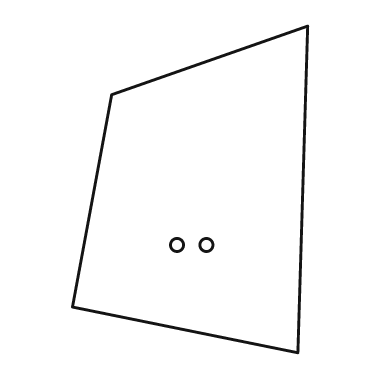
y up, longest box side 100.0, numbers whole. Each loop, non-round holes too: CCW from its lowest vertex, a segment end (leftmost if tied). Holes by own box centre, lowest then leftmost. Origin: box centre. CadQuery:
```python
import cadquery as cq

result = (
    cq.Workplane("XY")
    .moveTo(33.0, -50.0)
    .lineTo(36.0, 50.0)
    .lineTo(-24.0, 29.0)
    .lineTo(-36.0, -36.0)
    .close()
    .moveTo(-4.0, -17.0)
    .circle(2.0)
    .moveTo(5.0, -17.0)
    .circle(2.0)
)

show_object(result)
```